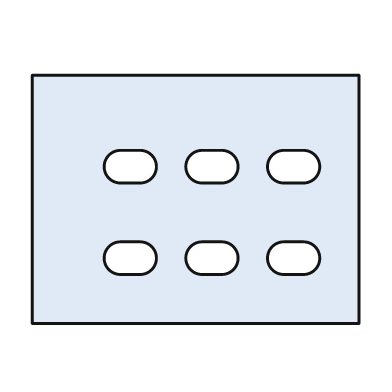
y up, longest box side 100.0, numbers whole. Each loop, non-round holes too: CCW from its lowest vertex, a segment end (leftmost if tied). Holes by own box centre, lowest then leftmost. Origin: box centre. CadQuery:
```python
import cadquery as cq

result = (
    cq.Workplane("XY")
    .moveTo(-50.0, -38.0)
    .lineTo(50.0, -38.0)
    .lineTo(50.0, 38.0)
    .lineTo(-50.0, 38.0)
    .close()
    .moveTo(-23.0, -23.0)
    .lineTo(-17.0, -23.0)
    .threePointArc((-12.0, -18.0), (-17.0, -13.0))
    .lineTo(-23.0, -13.0)
    .threePointArc((-28.0, -18.0), (-23.0, -23.0))
    .close()
    .moveTo(2.0, -23.0)
    .lineTo(8.0, -23.0)
    .threePointArc((13.0, -18.0), (8.0, -13.0))
    .lineTo(2.0, -13.0)
    .threePointArc((-3.0, -18.0), (2.0, -23.0))
    .close()
    .moveTo(27.0, -23.0)
    .lineTo(33.0, -23.0)
    .threePointArc((38.0, -18.0), (33.0, -13.0))
    .lineTo(27.0, -13.0)
    .threePointArc((22.0, -18.0), (27.0, -23.0))
    .close()
    .moveTo(-23.0, 5.0)
    .lineTo(-17.0, 5.0)
    .threePointArc((-12.0, 10.0), (-17.0, 15.0))
    .lineTo(-23.0, 15.0)
    .threePointArc((-28.0, 10.0), (-23.0, 5.0))
    .close()
    .moveTo(2.0, 5.0)
    .lineTo(8.0, 5.0)
    .threePointArc((13.0, 10.0), (8.0, 15.0))
    .lineTo(2.0, 15.0)
    .threePointArc((-3.0, 10.0), (2.0, 5.0))
    .close()
    .moveTo(27.0, 5.0)
    .lineTo(33.0, 5.0)
    .threePointArc((38.0, 10.0), (33.0, 15.0))
    .lineTo(27.0, 15.0)
    .threePointArc((22.0, 10.0), (27.0, 5.0))
    .close()
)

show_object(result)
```